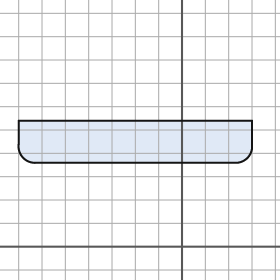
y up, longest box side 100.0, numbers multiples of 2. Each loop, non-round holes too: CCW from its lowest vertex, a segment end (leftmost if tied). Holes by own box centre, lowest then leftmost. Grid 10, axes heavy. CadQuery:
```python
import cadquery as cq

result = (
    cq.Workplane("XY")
    .moveTo(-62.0, 36.0)
    .lineTo(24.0, 36.0)
    .threePointArc((28.0, 38.0), (30.0, 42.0))
    .lineTo(30.0, 54.0)
    .lineTo(-70.0, 54.0)
    .lineTo(-70.0, 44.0)
    .threePointArc((-68.0, 38.0), (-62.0, 36.0))
    .close()
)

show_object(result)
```